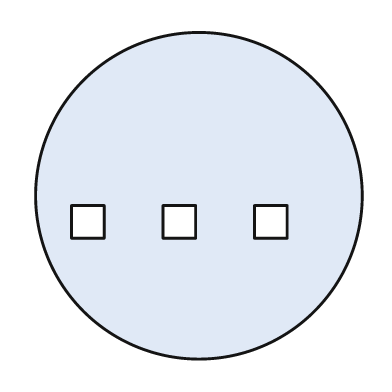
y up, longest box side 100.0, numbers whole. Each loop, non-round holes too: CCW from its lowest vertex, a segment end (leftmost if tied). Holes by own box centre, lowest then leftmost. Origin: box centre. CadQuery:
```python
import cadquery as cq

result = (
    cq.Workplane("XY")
    .moveTo(0.0, 0.0)
    .circle(50.0)
    .moveTo(-39.0, -13.0)
    .lineTo(-29.0, -13.0)
    .lineTo(-29.0, -3.0)
    .lineTo(-39.0, -3.0)
    .close()
    .moveTo(-11.0, -13.0)
    .lineTo(-1.0, -13.0)
    .lineTo(-1.0, -3.0)
    .lineTo(-11.0, -3.0)
    .close()
    .moveTo(17.0, -13.0)
    .lineTo(27.0, -13.0)
    .lineTo(27.0, -3.0)
    .lineTo(17.0, -3.0)
    .close()
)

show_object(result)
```